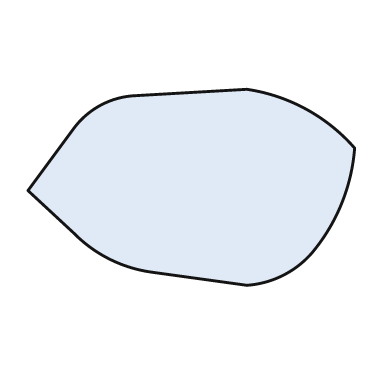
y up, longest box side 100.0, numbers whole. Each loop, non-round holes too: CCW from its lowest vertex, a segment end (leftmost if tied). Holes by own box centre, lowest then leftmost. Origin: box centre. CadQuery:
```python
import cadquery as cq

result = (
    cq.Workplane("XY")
    .moveTo(17.0, -30.0)
    .threePointArc((28.0, -27.0), (37.0, -20.0))
    .threePointArc((46.0, -5.0), (50.0, 12.0))
    .threePointArc((35.0, 24.0), (17.0, 30.0))
    .lineTo(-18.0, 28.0)
    .threePointArc((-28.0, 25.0), (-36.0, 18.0))
    .lineTo(-50.0, -1.0)
    .lineTo(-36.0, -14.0)
    .threePointArc((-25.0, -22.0), (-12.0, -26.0))
    .close()
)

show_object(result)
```